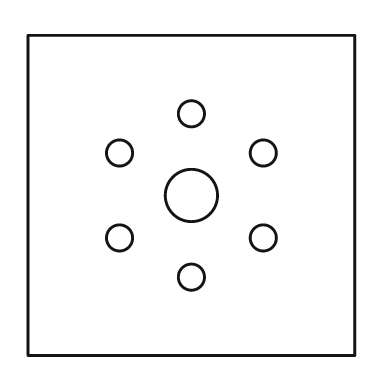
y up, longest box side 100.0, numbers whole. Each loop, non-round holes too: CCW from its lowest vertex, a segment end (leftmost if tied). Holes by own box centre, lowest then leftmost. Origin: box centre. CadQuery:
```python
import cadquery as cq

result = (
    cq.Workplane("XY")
    .moveTo(-50.0, -49.0)
    .lineTo(50.0, -49.0)
    .lineTo(50.0, 49.0)
    .lineTo(-50.0, 49.0)
    .close()
    .moveTo(0.0, -25.0)
    .circle(4.0)
    .moveTo(-22.0, -13.0)
    .circle(4.0)
    .moveTo(22.0, -13.0)
    .circle(4.0)
    .moveTo(0.0, 0.0)
    .circle(8.0)
    .moveTo(-22.0, 13.0)
    .circle(4.0)
    .moveTo(22.0, 13.0)
    .circle(4.0)
    .moveTo(0.0, 25.0)
    .circle(4.0)
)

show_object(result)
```